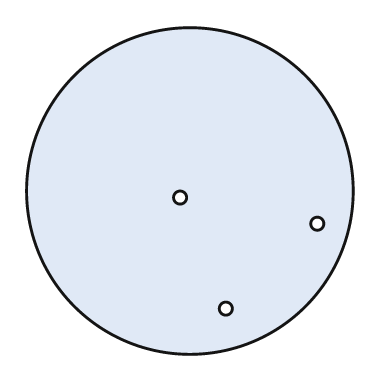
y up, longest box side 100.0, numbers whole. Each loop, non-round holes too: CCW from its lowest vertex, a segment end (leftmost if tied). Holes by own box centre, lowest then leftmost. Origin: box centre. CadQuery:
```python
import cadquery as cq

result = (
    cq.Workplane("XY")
    .moveTo(0.0, 0.0)
    .circle(50.0)
    .moveTo(11.0, -36.0)
    .circle(2.0)
    .moveTo(39.0, -10.0)
    .circle(2.0)
    .moveTo(-3.0, -2.0)
    .circle(2.0)
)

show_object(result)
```